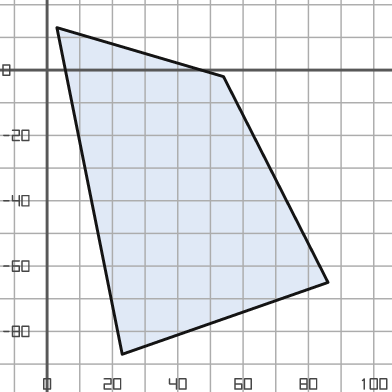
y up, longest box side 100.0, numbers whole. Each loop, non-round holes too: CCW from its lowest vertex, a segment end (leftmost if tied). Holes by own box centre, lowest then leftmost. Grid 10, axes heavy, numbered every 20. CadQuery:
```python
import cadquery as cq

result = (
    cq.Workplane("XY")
    .moveTo(23.0, -87.0)
    .lineTo(86.0, -65.0)
    .lineTo(54.0, -2.0)
    .lineTo(3.0, 13.0)
    .close()
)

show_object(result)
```